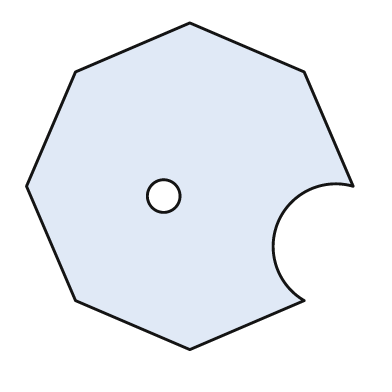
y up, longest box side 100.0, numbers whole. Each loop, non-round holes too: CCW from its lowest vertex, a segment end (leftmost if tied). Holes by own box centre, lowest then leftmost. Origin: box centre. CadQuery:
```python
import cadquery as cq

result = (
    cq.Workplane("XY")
    .moveTo(0.0, -50.0)
    .lineTo(35.0, -35.0)
    .threePointArc((27.0, -11.0), (50.0, 0.0))
    .lineTo(35.0, 35.0)
    .lineTo(0.0, 50.0)
    .lineTo(-35.0, 35.0)
    .lineTo(-50.0, 0.0)
    .lineTo(-35.0, -35.0)
    .close()
    .moveTo(-8.0, -3.0)
    .circle(5.0)
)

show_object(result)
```